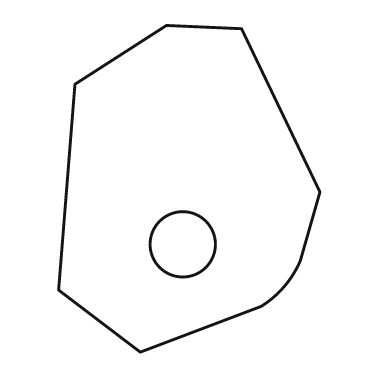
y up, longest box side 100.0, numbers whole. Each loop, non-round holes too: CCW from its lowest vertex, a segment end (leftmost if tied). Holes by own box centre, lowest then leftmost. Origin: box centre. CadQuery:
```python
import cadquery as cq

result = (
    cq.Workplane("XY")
    .moveTo(-15.0, -50.0)
    .lineTo(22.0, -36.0)
    .threePointArc((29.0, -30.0), (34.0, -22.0))
    .lineTo(40.0, -1.0)
    .lineTo(16.0, 49.0)
    .lineTo(-7.0, 50.0)
    .lineTo(-35.0, 32.0)
    .lineTo(-40.0, -31.0)
    .close()
    .moveTo(-2.0, -17.0)
    .circle(10.0)
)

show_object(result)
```